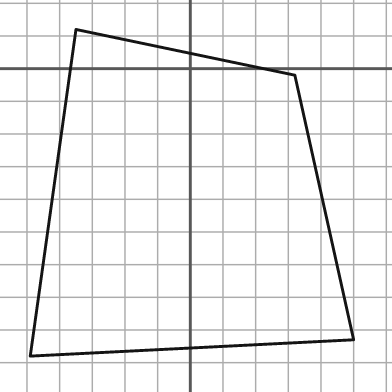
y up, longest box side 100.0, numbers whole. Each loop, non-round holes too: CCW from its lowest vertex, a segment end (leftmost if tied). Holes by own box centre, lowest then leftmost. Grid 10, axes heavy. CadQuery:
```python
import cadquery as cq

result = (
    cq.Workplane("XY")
    .moveTo(-49.0, -88.0)
    .lineTo(50.0, -83.0)
    .lineTo(32.0, -2.0)
    .lineTo(-35.0, 12.0)
    .close()
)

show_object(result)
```